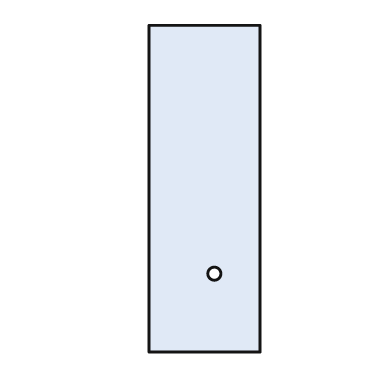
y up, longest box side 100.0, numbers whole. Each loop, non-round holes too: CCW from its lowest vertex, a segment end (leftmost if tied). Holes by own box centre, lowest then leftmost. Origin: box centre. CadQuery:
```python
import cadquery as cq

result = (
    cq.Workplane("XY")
    .moveTo(-17.0, -50.0)
    .lineTo(17.0, -50.0)
    .lineTo(17.0, 50.0)
    .lineTo(-17.0, 50.0)
    .close()
    .moveTo(3.0, -26.0)
    .circle(2.0)
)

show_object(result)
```